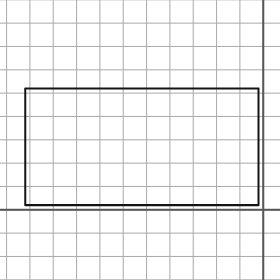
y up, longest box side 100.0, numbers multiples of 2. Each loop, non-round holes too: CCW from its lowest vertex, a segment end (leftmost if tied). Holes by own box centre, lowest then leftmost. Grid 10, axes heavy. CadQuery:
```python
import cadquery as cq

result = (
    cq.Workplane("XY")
    .moveTo(-102.0, 2.0)
    .lineTo(-2.0, 2.0)
    .lineTo(-2.0, 52.0)
    .lineTo(-102.0, 52.0)
    .close()
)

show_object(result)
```